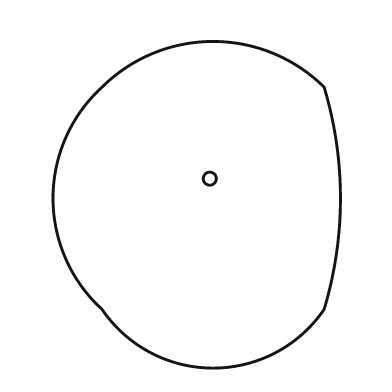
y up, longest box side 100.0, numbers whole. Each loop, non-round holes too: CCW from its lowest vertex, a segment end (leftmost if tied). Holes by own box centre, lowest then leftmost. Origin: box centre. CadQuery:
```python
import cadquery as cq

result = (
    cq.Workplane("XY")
    .moveTo(-29.0, -32.0)
    .threePointArc((5.0, -50.0), (39.0, -32.0))
    .threePointArc((44.0, 2.0), (39.0, 36.0))
    .threePointArc((5.0, 50.0), (-29.0, 36.0))
    .threePointArc((-44.0, 2.0), (-29.0, -32.0))
    .close()
    .moveTo(4.0, 8.0)
    .circle(2.0)
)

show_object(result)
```